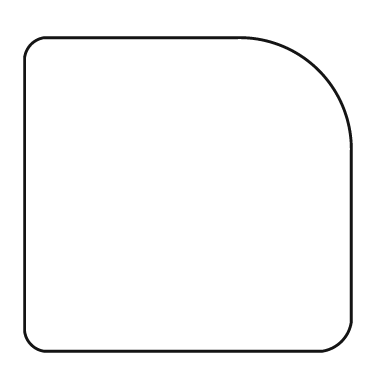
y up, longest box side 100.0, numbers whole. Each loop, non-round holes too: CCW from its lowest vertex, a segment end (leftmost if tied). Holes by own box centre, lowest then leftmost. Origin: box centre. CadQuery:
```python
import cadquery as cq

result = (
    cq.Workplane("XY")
    .moveTo(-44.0, -48.0)
    .lineTo(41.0, -48.0)
    .threePointArc((47.0, -45.0), (50.0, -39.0))
    .lineTo(50.0, 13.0)
    .threePointArc((40.0, 38.0), (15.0, 48.0))
    .lineTo(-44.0, 48.0)
    .threePointArc((-48.0, 46.0), (-50.0, 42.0))
    .lineTo(-50.0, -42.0)
    .threePointArc((-48.0, -46.0), (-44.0, -48.0))
    .close()
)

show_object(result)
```